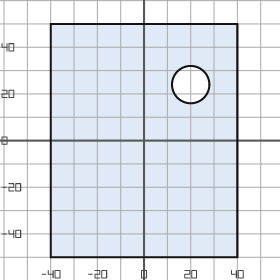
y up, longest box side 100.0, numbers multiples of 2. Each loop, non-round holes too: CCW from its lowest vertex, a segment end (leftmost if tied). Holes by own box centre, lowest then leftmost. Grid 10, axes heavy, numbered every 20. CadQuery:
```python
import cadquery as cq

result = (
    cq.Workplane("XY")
    .moveTo(-40.0, -50.0)
    .lineTo(40.0, -50.0)
    .lineTo(40.0, 50.0)
    .lineTo(-40.0, 50.0)
    .close()
    .moveTo(20.0, 24.0)
    .circle(8.0)
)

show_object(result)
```